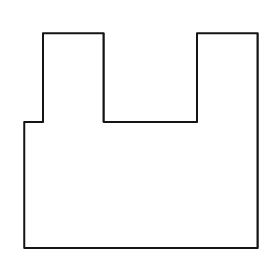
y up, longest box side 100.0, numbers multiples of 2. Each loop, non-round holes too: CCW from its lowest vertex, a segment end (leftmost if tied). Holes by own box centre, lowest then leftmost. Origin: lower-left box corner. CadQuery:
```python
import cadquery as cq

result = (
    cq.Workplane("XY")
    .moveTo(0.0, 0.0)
    .lineTo(100.0, 0.0)
    .lineTo(100.0, 92.0)
    .lineTo(74.0, 92.0)
    .lineTo(74.0, 54.0)
    .lineTo(34.0, 54.0)
    .lineTo(34.0, 92.0)
    .lineTo(8.0, 92.0)
    .lineTo(8.0, 54.0)
    .lineTo(0.0, 54.0)
    .close()
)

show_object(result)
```